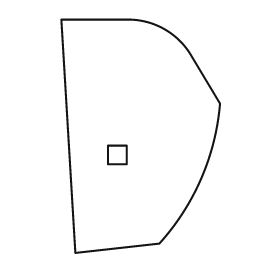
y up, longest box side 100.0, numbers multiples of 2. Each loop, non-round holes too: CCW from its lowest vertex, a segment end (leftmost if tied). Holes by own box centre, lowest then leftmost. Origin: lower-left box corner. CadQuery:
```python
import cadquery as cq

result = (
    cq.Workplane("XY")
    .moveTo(6.0, 0.0)
    .lineTo(42.0, 4.0)
    .threePointArc((60.0, 32.0), (68.0, 64.0))
    .lineTo(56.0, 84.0)
    .threePointArc((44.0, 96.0), (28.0, 100.0))
    .lineTo(0.0, 100.0)
    .close()
    .moveTo(20.0, 38.0)
    .lineTo(28.0, 38.0)
    .lineTo(28.0, 46.0)
    .lineTo(20.0, 46.0)
    .close()
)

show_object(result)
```